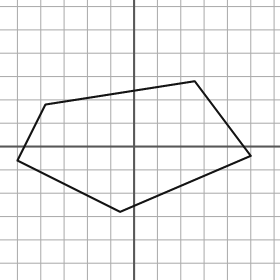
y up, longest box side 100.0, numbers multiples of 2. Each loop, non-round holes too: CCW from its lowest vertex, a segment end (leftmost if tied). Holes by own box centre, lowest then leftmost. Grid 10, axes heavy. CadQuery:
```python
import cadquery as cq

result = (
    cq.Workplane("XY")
    .moveTo(-6.0, -28.0)
    .lineTo(50.0, -4.0)
    .lineTo(26.0, 28.0)
    .lineTo(-38.0, 18.0)
    .lineTo(-50.0, -6.0)
    .close()
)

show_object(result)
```